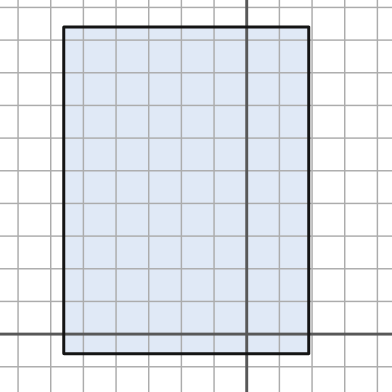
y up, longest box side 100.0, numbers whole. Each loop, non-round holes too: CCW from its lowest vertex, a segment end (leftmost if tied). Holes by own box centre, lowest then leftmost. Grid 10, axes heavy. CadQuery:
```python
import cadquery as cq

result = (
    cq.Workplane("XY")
    .moveTo(-56.0, -6.0)
    .lineTo(19.0, -6.0)
    .lineTo(19.0, 94.0)
    .lineTo(-56.0, 94.0)
    .close()
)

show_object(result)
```